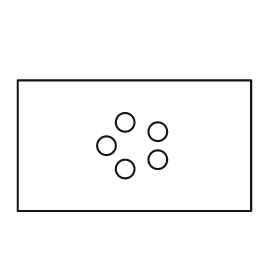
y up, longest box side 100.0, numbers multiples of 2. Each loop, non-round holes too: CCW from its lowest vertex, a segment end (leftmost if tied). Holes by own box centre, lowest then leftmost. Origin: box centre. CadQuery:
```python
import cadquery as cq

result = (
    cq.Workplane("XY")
    .moveTo(-50.0, -28.0)
    .lineTo(50.0, -28.0)
    .lineTo(50.0, 28.0)
    .lineTo(-50.0, 28.0)
    .close()
    .moveTo(-4.0, -10.0)
    .circle(4.0)
    .moveTo(10.0, -6.0)
    .circle(4.0)
    .moveTo(-12.0, 0.0)
    .circle(4.0)
    .moveTo(10.0, 6.0)
    .circle(4.0)
    .moveTo(-4.0, 10.0)
    .circle(4.0)
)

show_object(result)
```